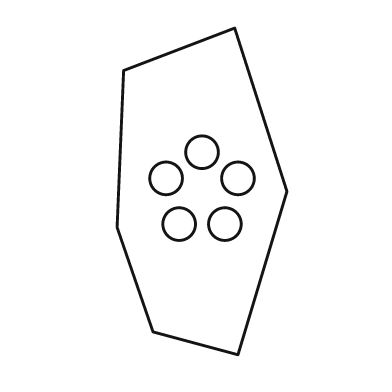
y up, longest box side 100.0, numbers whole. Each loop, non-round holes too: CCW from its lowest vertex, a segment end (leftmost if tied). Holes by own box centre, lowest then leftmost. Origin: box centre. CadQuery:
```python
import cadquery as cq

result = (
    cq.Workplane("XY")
    .moveTo(11.0, -50.0)
    .lineTo(26.0, 0.0)
    .lineTo(10.0, 50.0)
    .lineTo(-24.0, 37.0)
    .lineTo(-26.0, -11.0)
    .lineTo(-15.0, -43.0)
    .close()
    .moveTo(-7.0, -10.0)
    .circle(5.0)
    .moveTo(7.0, -10.0)
    .circle(5.0)
    .moveTo(-11.0, 4.0)
    .circle(5.0)
    .moveTo(11.0, 4.0)
    .circle(5.0)
    .moveTo(0.0, 12.0)
    .circle(5.0)
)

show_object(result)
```